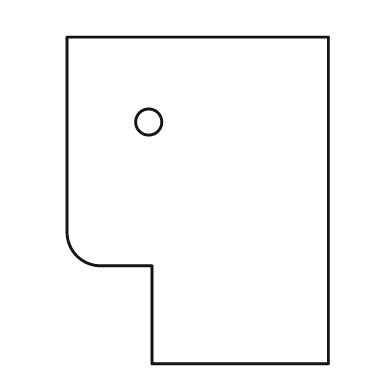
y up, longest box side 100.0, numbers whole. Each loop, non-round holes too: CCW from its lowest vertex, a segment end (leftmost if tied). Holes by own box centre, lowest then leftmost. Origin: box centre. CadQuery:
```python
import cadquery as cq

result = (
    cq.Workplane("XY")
    .moveTo(-14.0, -50.0)
    .lineTo(40.0, -50.0)
    .lineTo(40.0, 50.0)
    .lineTo(-40.0, 50.0)
    .lineTo(-40.0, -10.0)
    .threePointArc((-37.0, -17.0), (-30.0, -20.0))
    .lineTo(-14.0, -20.0)
    .close()
    .moveTo(-15.0, 24.0)
    .circle(4.0)
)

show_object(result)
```